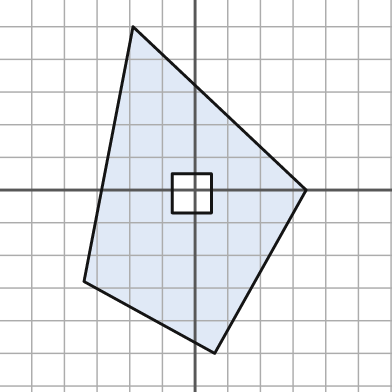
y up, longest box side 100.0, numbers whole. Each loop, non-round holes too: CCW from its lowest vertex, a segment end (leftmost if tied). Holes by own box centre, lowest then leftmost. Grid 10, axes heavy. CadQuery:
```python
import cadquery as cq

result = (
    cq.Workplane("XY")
    .moveTo(6.0, -50.0)
    .lineTo(34.0, 0.0)
    .lineTo(-19.0, 50.0)
    .lineTo(-34.0, -28.0)
    .close()
    .moveTo(-7.0, -7.0)
    .lineTo(5.0, -7.0)
    .lineTo(5.0, 5.0)
    .lineTo(-7.0, 5.0)
    .close()
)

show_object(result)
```